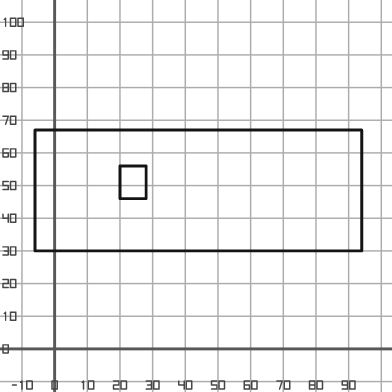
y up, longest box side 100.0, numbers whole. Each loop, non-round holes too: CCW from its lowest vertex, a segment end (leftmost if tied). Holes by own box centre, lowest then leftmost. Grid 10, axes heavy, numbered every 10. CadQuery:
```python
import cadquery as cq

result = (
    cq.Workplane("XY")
    .moveTo(-6.0, 30.0)
    .lineTo(94.0, 30.0)
    .lineTo(94.0, 67.0)
    .lineTo(-6.0, 67.0)
    .close()
    .moveTo(20.0, 46.0)
    .lineTo(28.0, 46.0)
    .lineTo(28.0, 56.0)
    .lineTo(20.0, 56.0)
    .close()
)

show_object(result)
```